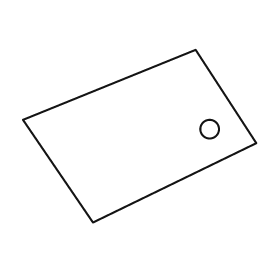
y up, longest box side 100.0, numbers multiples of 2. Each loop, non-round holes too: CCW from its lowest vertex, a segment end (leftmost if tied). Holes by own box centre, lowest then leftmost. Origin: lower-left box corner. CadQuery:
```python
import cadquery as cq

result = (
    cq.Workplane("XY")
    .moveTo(30.0, 0.0)
    .lineTo(100.0, 34.0)
    .lineTo(74.0, 74.0)
    .lineTo(0.0, 44.0)
    .close()
    .moveTo(80.0, 40.0)
    .circle(4.0)
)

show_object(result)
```